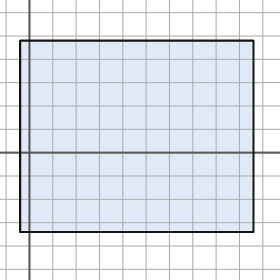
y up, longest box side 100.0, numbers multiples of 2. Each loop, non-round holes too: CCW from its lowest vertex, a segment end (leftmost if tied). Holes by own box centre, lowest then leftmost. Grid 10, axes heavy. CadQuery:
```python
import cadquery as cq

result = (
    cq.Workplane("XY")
    .moveTo(-4.0, -34.0)
    .lineTo(96.0, -34.0)
    .lineTo(96.0, 48.0)
    .lineTo(-4.0, 48.0)
    .close()
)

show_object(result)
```